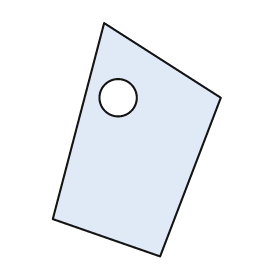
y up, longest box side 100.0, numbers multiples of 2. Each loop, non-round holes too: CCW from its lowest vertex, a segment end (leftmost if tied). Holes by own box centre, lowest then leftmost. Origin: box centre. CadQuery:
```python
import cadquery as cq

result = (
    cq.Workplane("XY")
    .moveTo(10.0, -50.0)
    .lineTo(36.0, 18.0)
    .lineTo(-14.0, 50.0)
    .lineTo(-36.0, -34.0)
    .close()
    .moveTo(-8.0, 18.0)
    .circle(8.0)
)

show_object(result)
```